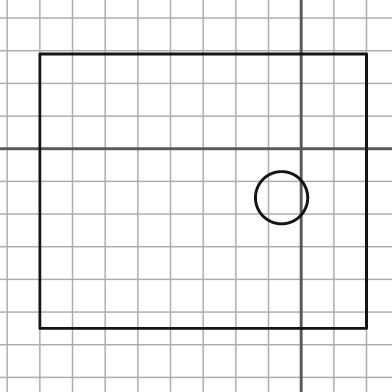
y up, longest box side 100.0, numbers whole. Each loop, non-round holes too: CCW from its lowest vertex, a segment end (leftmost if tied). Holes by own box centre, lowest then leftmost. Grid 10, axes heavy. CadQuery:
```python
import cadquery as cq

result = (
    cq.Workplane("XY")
    .moveTo(-80.0, -55.0)
    .lineTo(20.0, -55.0)
    .lineTo(20.0, 29.0)
    .lineTo(-80.0, 29.0)
    .close()
    .moveTo(-6.0, -15.0)
    .circle(8.0)
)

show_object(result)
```